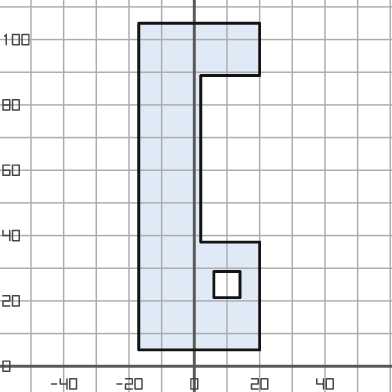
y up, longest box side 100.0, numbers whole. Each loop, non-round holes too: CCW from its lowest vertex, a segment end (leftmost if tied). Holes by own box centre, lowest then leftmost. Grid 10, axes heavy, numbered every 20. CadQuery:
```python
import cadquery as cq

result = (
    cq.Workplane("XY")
    .moveTo(-17.0, 5.0)
    .lineTo(20.0, 5.0)
    .lineTo(20.0, 38.0)
    .lineTo(2.0, 38.0)
    .lineTo(2.0, 89.0)
    .lineTo(20.0, 89.0)
    .lineTo(20.0, 105.0)
    .lineTo(-17.0, 105.0)
    .close()
    .moveTo(6.0, 21.0)
    .lineTo(14.0, 21.0)
    .lineTo(14.0, 29.0)
    .lineTo(6.0, 29.0)
    .close()
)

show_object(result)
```